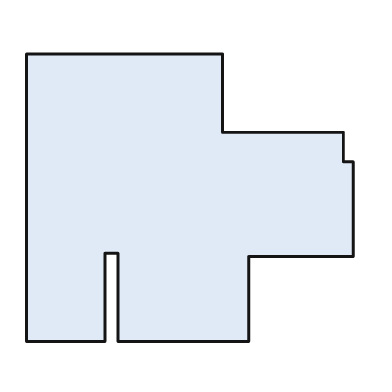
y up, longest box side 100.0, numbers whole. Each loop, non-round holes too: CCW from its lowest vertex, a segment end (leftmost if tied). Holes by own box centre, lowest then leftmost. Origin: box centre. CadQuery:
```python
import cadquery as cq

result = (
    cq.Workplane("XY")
    .moveTo(-50.0, -44.0)
    .lineTo(-26.0, -44.0)
    .lineTo(-26.0, -17.0)
    .lineTo(-22.0, -17.0)
    .lineTo(-22.0, -44.0)
    .lineTo(18.0, -44.0)
    .lineTo(18.0, -18.0)
    .lineTo(50.0, -18.0)
    .lineTo(50.0, 11.0)
    .lineTo(47.0, 11.0)
    .lineTo(47.0, 20.0)
    .lineTo(10.0, 20.0)
    .lineTo(10.0, 44.0)
    .lineTo(-50.0, 44.0)
    .close()
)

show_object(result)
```